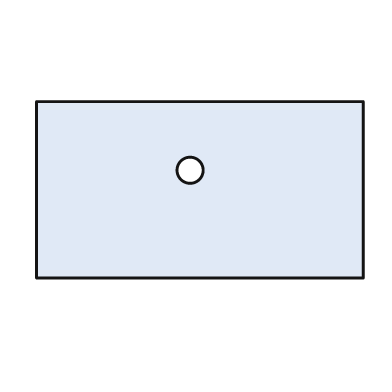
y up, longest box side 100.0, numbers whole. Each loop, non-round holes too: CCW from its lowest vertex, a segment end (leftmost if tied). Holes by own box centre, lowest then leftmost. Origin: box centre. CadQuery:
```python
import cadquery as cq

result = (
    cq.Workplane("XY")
    .moveTo(-50.0, -27.0)
    .lineTo(50.0, -27.0)
    .lineTo(50.0, 27.0)
    .lineTo(-50.0, 27.0)
    .close()
    .moveTo(-3.0, 6.0)
    .circle(4.0)
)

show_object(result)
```